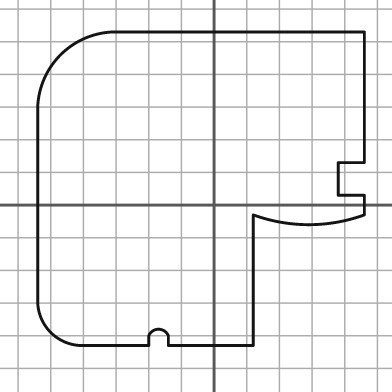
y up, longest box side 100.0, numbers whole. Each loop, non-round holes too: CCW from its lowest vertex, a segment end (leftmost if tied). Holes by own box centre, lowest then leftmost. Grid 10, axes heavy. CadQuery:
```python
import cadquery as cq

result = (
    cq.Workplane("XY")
    .moveTo(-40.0, -43.0)
    .lineTo(-20.0, -43.0)
    .lineTo(-20.0, -40.0)
    .threePointArc((-17.0, -38.0), (-14.0, -40.0))
    .lineTo(-14.0, -43.0)
    .lineTo(12.0, -43.0)
    .lineTo(12.0, -3.0)
    .threePointArc((29.0, -6.0), (46.0, -3.0))
    .lineTo(46.0, 3.0)
    .lineTo(38.0, 3.0)
    .lineTo(38.0, 13.0)
    .lineTo(46.0, 13.0)
    .lineTo(46.0, 53.0)
    .lineTo(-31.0, 53.0)
    .threePointArc((-47.0, 46.0), (-54.0, 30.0))
    .lineTo(-54.0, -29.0)
    .threePointArc((-50.0, -39.0), (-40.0, -43.0))
    .close()
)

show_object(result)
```